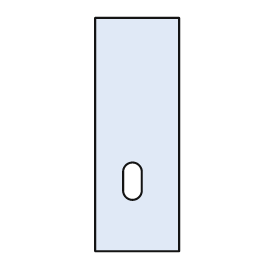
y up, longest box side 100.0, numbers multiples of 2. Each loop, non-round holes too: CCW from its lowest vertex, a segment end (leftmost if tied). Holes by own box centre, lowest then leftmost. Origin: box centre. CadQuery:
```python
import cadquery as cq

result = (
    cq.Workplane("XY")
    .moveTo(-18.0, -50.0)
    .lineTo(18.0, -50.0)
    .lineTo(18.0, 50.0)
    .lineTo(-18.0, 50.0)
    .close()
    .moveTo(-6.0, -24.0)
    .threePointArc((-2.0, -28.0), (2.0, -24.0))
    .lineTo(2.0, -16.0)
    .threePointArc((-2.0, -12.0), (-6.0, -16.0))
    .close()
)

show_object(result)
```